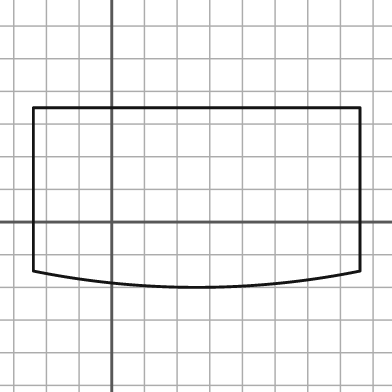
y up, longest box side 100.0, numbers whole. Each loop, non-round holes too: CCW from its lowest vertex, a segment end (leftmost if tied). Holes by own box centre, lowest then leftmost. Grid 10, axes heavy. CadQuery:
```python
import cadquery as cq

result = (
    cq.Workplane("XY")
    .moveTo(-24.0, -15.0)
    .threePointArc((26.0, -20.0), (76.0, -15.0))
    .lineTo(76.0, 35.0)
    .lineTo(-24.0, 35.0)
    .close()
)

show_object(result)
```